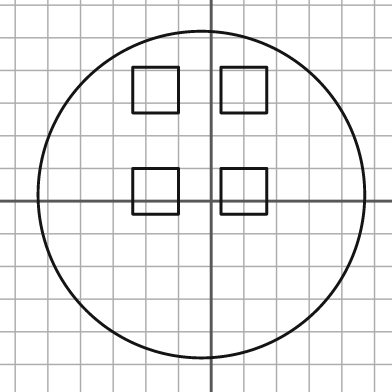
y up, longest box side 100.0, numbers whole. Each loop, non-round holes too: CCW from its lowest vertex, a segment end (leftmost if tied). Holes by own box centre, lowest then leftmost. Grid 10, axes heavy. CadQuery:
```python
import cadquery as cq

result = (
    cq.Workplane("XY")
    .moveTo(-3.0, 2.0)
    .circle(50.0)
    .moveTo(-24.0, -4.0)
    .lineTo(-10.0, -4.0)
    .lineTo(-10.0, 10.0)
    .lineTo(-24.0, 10.0)
    .close()
    .moveTo(3.0, -4.0)
    .lineTo(17.0, -4.0)
    .lineTo(17.0, 10.0)
    .lineTo(3.0, 10.0)
    .close()
    .moveTo(-24.0, 27.0)
    .lineTo(-10.0, 27.0)
    .lineTo(-10.0, 41.0)
    .lineTo(-24.0, 41.0)
    .close()
    .moveTo(3.0, 27.0)
    .lineTo(17.0, 27.0)
    .lineTo(17.0, 41.0)
    .lineTo(3.0, 41.0)
    .close()
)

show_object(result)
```